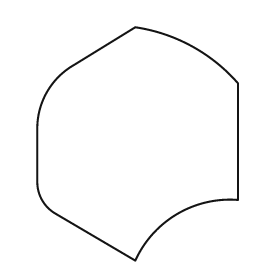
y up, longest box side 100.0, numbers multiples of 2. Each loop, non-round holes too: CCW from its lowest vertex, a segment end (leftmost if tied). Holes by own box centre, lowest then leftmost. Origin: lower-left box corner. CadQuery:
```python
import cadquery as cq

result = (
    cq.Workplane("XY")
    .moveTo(42.0, 0.0)
    .threePointArc((60.0, 20.0), (86.0, 26.0))
    .lineTo(86.0, 76.0)
    .threePointArc((66.0, 92.0), (42.0, 100.0))
    .lineTo(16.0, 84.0)
    .threePointArc((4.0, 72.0), (0.0, 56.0))
    .lineTo(0.0, 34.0)
    .threePointArc((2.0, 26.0), (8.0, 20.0))
    .close()
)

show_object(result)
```